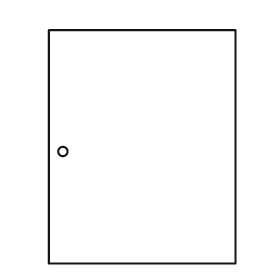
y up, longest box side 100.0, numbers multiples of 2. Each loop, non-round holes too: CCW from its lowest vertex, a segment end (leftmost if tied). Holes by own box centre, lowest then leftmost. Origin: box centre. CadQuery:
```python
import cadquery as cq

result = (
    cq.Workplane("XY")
    .moveTo(-40.0, -50.0)
    .lineTo(40.0, -50.0)
    .lineTo(40.0, 50.0)
    .lineTo(-40.0, 50.0)
    .close()
    .moveTo(-34.0, -2.0)
    .circle(2.0)
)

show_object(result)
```